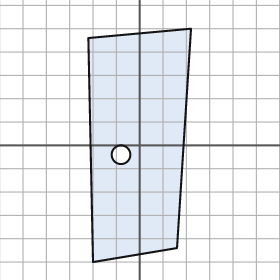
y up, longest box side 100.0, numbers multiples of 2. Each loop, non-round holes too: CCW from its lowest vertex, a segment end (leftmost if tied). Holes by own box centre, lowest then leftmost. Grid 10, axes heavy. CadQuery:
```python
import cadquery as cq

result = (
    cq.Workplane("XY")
    .moveTo(-20.0, -50.0)
    .lineTo(16.0, -44.0)
    .lineTo(22.0, 50.0)
    .lineTo(-22.0, 46.0)
    .close()
    .moveTo(-8.0, -4.0)
    .circle(4.0)
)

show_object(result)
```